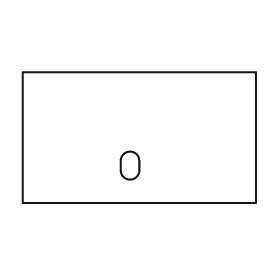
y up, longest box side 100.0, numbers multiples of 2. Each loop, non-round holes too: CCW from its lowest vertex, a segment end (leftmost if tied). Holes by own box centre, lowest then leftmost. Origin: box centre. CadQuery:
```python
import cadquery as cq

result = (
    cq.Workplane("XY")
    .moveTo(-50.0, -28.0)
    .lineTo(50.0, -28.0)
    .lineTo(50.0, 28.0)
    .lineTo(-50.0, 28.0)
    .close()
    .moveTo(-8.0, -14.0)
    .threePointArc((-4.0, -18.0), (0.0, -14.0))
    .lineTo(0.0, -10.0)
    .threePointArc((-4.0, -6.0), (-8.0, -10.0))
    .close()
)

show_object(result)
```